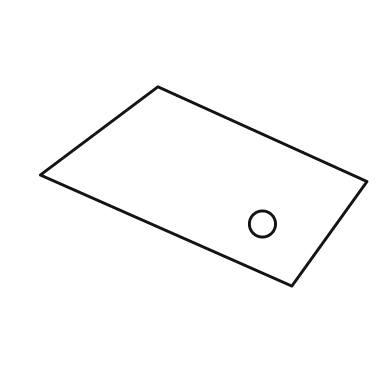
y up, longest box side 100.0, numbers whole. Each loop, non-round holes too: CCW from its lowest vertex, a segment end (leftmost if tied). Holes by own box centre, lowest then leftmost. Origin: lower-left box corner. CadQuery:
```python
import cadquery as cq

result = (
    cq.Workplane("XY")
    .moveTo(77.0, 0.0)
    .lineTo(100.0, 32.0)
    .lineTo(36.0, 61.0)
    .lineTo(0.0, 34.0)
    .close()
    .moveTo(68.0, 19.0)
    .circle(4.0)
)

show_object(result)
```